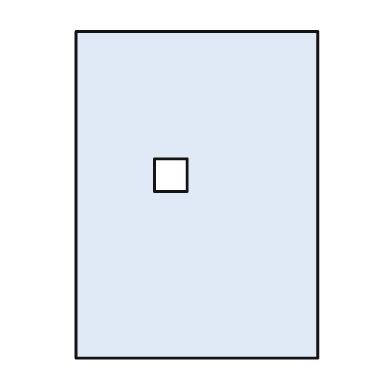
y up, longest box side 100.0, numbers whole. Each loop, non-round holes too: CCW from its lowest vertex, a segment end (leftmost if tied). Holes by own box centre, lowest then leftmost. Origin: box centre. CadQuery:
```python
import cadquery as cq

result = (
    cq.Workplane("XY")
    .moveTo(-37.0, -50.0)
    .lineTo(37.0, -50.0)
    .lineTo(37.0, 50.0)
    .lineTo(-37.0, 50.0)
    .close()
    .moveTo(-13.0, 1.0)
    .lineTo(-3.0, 1.0)
    .lineTo(-3.0, 11.0)
    .lineTo(-13.0, 11.0)
    .close()
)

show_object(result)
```